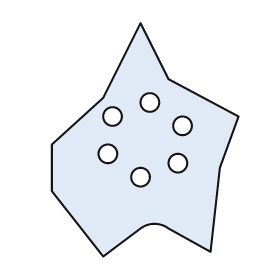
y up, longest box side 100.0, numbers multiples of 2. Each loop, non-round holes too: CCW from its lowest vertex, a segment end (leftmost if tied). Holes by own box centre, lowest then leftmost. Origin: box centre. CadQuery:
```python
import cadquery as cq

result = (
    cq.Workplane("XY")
    .moveTo(-18.0, -50.0)
    .lineTo(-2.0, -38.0)
    .threePointArc((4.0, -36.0), (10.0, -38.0))
    .lineTo(28.0, -48.0)
    .lineTo(32.0, -12.0)
    .lineTo(40.0, 10.0)
    .lineTo(10.0, 26.0)
    .lineTo(-2.0, 50.0)
    .lineTo(-18.0, 18.0)
    .lineTo(-40.0, -2.0)
    .lineTo(-40.0, -22.0)
    .close()
    .moveTo(-2.0, -16.0)
    .circle(4.0)
    .moveTo(14.0, -10.0)
    .circle(4.0)
    .moveTo(-16.0, -6.0)
    .circle(4.0)
    .moveTo(16.0, 6.0)
    .circle(4.0)
    .moveTo(-14.0, 10.0)
    .circle(4.0)
    .moveTo(2.0, 16.0)
    .circle(4.0)
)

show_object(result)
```